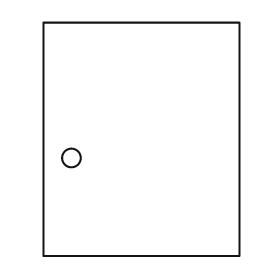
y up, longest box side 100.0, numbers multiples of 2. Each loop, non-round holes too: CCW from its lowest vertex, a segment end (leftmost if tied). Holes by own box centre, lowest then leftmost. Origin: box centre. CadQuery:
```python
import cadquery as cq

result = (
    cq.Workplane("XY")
    .moveTo(-42.0, -50.0)
    .lineTo(42.0, -50.0)
    .lineTo(42.0, 50.0)
    .lineTo(-42.0, 50.0)
    .close()
    .moveTo(-30.0, -8.0)
    .circle(4.0)
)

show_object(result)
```